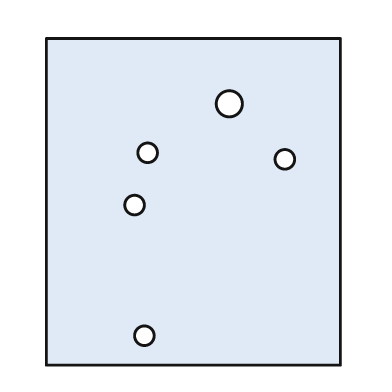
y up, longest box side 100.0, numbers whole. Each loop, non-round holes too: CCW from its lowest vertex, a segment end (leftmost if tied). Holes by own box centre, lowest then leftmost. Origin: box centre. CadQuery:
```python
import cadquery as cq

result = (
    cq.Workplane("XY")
    .moveTo(-45.0, -50.0)
    .lineTo(45.0, -50.0)
    .lineTo(45.0, 50.0)
    .lineTo(-45.0, 50.0)
    .close()
    .moveTo(-15.0, -41.0)
    .circle(3.0)
    .moveTo(-18.0, -1.0)
    .circle(3.0)
    .moveTo(28.0, 13.0)
    .circle(3.0)
    .moveTo(-14.0, 15.0)
    .circle(3.0)
    .moveTo(11.0, 30.0)
    .circle(4.0)
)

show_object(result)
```